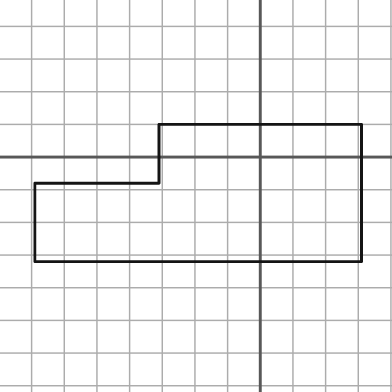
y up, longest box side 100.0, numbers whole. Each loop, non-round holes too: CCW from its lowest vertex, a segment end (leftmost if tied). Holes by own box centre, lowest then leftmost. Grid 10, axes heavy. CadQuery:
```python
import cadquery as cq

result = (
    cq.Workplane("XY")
    .moveTo(-69.0, -32.0)
    .lineTo(31.0, -32.0)
    .lineTo(31.0, 10.0)
    .lineTo(-31.0, 10.0)
    .lineTo(-31.0, -8.0)
    .lineTo(-69.0, -8.0)
    .close()
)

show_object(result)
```